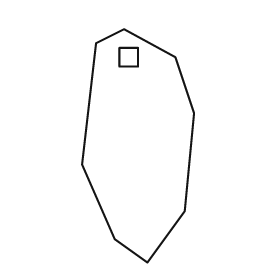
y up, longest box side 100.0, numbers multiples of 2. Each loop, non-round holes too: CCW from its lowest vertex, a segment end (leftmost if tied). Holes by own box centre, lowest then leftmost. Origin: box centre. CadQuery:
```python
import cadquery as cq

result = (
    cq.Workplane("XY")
    .moveTo(4.0, -50.0)
    .lineTo(20.0, -28.0)
    .lineTo(24.0, 14.0)
    .lineTo(16.0, 38.0)
    .lineTo(-6.0, 50.0)
    .lineTo(-18.0, 44.0)
    .lineTo(-24.0, -8.0)
    .lineTo(-10.0, -40.0)
    .close()
    .moveTo(-8.0, 34.0)
    .lineTo(0.0, 34.0)
    .lineTo(0.0, 42.0)
    .lineTo(-8.0, 42.0)
    .close()
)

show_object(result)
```